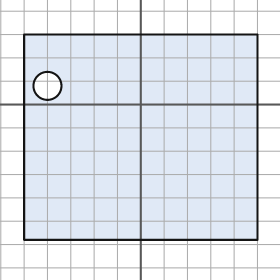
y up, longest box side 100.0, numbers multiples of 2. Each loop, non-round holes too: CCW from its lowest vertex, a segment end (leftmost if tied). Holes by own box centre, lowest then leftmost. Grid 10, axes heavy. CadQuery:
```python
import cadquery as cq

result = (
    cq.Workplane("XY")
    .moveTo(-50.0, -58.0)
    .lineTo(50.0, -58.0)
    .lineTo(50.0, 30.0)
    .lineTo(-50.0, 30.0)
    .close()
    .moveTo(-40.0, 8.0)
    .circle(6.0)
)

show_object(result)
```